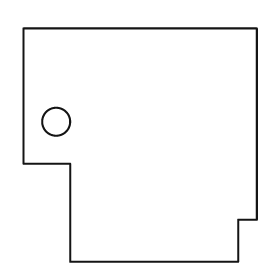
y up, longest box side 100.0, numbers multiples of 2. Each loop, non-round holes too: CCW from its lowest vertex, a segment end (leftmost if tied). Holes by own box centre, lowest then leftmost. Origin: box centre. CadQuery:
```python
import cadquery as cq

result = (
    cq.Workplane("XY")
    .moveTo(-30.0, -50.0)
    .lineTo(42.0, -50.0)
    .lineTo(42.0, -32.0)
    .lineTo(50.0, -32.0)
    .lineTo(50.0, 50.0)
    .lineTo(-50.0, 50.0)
    .lineTo(-50.0, -8.0)
    .lineTo(-30.0, -8.0)
    .close()
    .moveTo(-36.0, 10.0)
    .circle(6.0)
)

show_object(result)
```